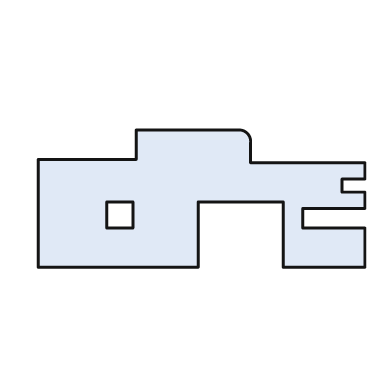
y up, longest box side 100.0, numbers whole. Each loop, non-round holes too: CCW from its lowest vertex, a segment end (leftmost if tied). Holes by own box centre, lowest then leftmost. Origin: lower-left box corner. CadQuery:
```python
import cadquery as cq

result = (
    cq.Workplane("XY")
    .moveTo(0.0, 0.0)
    .lineTo(49.0, 0.0)
    .lineTo(49.0, 20.0)
    .lineTo(75.0, 20.0)
    .lineTo(75.0, 0.0)
    .lineTo(100.0, 0.0)
    .lineTo(100.0, 12.0)
    .lineTo(81.0, 12.0)
    .lineTo(81.0, 18.0)
    .lineTo(100.0, 18.0)
    .lineTo(100.0, 23.0)
    .lineTo(93.0, 23.0)
    .lineTo(93.0, 27.0)
    .lineTo(100.0, 27.0)
    .lineTo(100.0, 32.0)
    .lineTo(65.0, 32.0)
    .lineTo(65.0, 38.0)
    .threePointArc((64.0, 41.0), (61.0, 42.0))
    .lineTo(30.0, 42.0)
    .lineTo(30.0, 33.0)
    .lineTo(0.0, 33.0)
    .close()
    .moveTo(21.0, 12.0)
    .lineTo(29.0, 12.0)
    .lineTo(29.0, 20.0)
    .lineTo(21.0, 20.0)
    .close()
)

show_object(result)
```